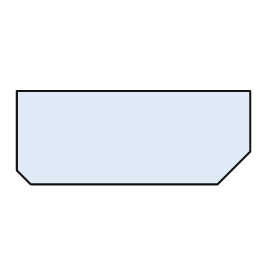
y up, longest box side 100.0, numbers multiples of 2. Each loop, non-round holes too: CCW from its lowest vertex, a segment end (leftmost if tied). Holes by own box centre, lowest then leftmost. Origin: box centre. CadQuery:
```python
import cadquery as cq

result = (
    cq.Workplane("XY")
    .moveTo(-44.0, -20.0)
    .lineTo(36.0, -20.0)
    .lineTo(50.0, -6.0)
    .lineTo(50.0, 20.0)
    .lineTo(-50.0, 20.0)
    .lineTo(-50.0, -14.0)
    .close()
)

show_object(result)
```